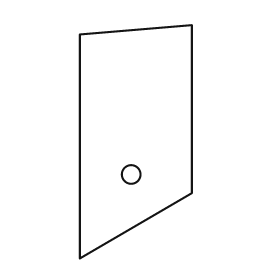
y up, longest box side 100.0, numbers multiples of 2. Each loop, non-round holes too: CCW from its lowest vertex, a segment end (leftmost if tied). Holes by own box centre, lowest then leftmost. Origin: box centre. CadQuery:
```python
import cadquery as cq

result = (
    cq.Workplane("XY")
    .moveTo(-24.0, -50.0)
    .lineTo(24.0, -22.0)
    .lineTo(24.0, 50.0)
    .lineTo(-24.0, 46.0)
    .close()
    .moveTo(-2.0, -14.0)
    .circle(4.0)
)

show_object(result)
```